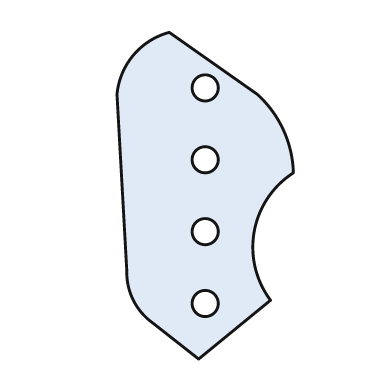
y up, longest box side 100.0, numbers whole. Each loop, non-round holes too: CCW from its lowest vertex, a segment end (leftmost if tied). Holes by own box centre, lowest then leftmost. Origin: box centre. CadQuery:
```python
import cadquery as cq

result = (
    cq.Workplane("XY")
    .moveTo(-2.0, -50.0)
    .lineTo(20.0, -32.0)
    .threePointArc((15.0, -11.0), (27.0, 7.0))
    .threePointArc((24.0, 20.0), (16.0, 31.0))
    .lineTo(-11.0, 50.0)
    .threePointArc((-22.0, 43.0), (-27.0, 31.0))
    .lineTo(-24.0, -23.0)
    .threePointArc((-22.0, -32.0), (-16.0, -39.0))
    .close()
    .moveTo(0.0, -33.0)
    .circle(4.0)
    .moveTo(0.0, -11.0)
    .circle(4.0)
    .moveTo(0.0, 11.0)
    .circle(4.0)
    .moveTo(0.0, 33.0)
    .circle(4.0)
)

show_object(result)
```